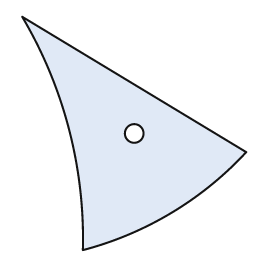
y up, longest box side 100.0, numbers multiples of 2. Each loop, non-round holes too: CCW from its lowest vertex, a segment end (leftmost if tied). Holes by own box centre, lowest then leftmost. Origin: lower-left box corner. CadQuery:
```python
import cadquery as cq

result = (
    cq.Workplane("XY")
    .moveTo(26.0, 0.0)
    .threePointArc((64.0, 16.0), (96.0, 42.0))
    .lineTo(0.0, 100.0)
    .threePointArc((20.0, 52.0), (26.0, 0.0))
    .close()
    .moveTo(48.0, 50.0)
    .circle(4.0)
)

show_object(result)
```